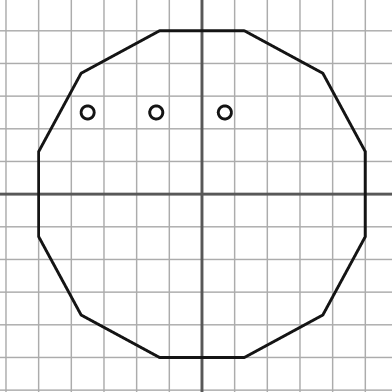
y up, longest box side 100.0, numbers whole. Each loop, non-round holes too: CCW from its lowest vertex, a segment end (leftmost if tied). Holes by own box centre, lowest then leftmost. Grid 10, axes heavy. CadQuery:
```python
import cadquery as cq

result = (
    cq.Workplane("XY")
    .moveTo(-13.0, -50.0)
    .lineTo(13.0, -50.0)
    .lineTo(37.0, -37.0)
    .lineTo(50.0, -13.0)
    .lineTo(50.0, 13.0)
    .lineTo(37.0, 37.0)
    .lineTo(13.0, 50.0)
    .lineTo(-13.0, 50.0)
    .lineTo(-37.0, 37.0)
    .lineTo(-50.0, 13.0)
    .lineTo(-50.0, -13.0)
    .lineTo(-37.0, -37.0)
    .close()
    .moveTo(-35.0, 25.0)
    .circle(2.0)
    .moveTo(-14.0, 25.0)
    .circle(2.0)
    .moveTo(7.0, 25.0)
    .circle(2.0)
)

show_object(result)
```